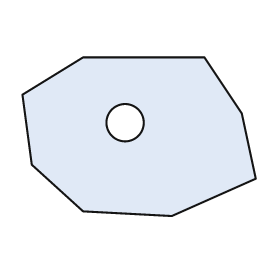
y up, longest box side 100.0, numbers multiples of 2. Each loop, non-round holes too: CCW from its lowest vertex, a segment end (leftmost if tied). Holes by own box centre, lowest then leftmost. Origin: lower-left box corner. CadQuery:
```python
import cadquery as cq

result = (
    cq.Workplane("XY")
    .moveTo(64.0, 0.0)
    .lineTo(100.0, 16.0)
    .lineTo(94.0, 44.0)
    .lineTo(78.0, 68.0)
    .lineTo(26.0, 68.0)
    .lineTo(0.0, 52.0)
    .lineTo(4.0, 22.0)
    .lineTo(26.0, 2.0)
    .close()
    .moveTo(44.0, 40.0)
    .circle(8.0)
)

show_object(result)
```